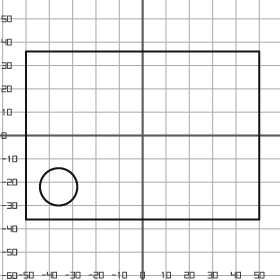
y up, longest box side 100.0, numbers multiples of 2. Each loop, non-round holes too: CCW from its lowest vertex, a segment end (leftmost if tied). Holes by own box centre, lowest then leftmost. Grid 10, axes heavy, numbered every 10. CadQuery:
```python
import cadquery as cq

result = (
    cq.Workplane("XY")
    .moveTo(-50.0, -36.0)
    .lineTo(50.0, -36.0)
    .lineTo(50.0, 36.0)
    .lineTo(-50.0, 36.0)
    .close()
    .moveTo(-36.0, -22.0)
    .circle(8.0)
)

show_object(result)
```